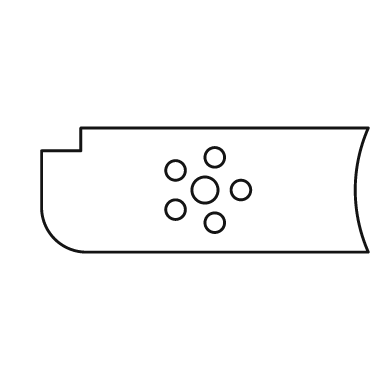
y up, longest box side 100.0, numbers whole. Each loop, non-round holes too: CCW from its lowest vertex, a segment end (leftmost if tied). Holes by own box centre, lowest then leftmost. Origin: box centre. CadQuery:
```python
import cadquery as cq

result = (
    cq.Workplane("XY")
    .moveTo(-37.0, -19.0)
    .lineTo(50.0, -19.0)
    .threePointArc((46.0, 0.0), (50.0, 19.0))
    .lineTo(-38.0, 19.0)
    .lineTo(-38.0, 12.0)
    .lineTo(-50.0, 12.0)
    .lineTo(-50.0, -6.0)
    .threePointArc((-46.0, -15.0), (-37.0, -19.0))
    .close()
    .moveTo(3.0, -10.0)
    .circle(3.0)
    .moveTo(-9.0, -6.0)
    .circle(3.0)
    .moveTo(0.0, 0.0)
    .circle(4.0)
    .moveTo(11.0, 0.0)
    .circle(3.0)
    .moveTo(-9.0, 6.0)
    .circle(3.0)
    .moveTo(3.0, 10.0)
    .circle(3.0)
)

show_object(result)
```